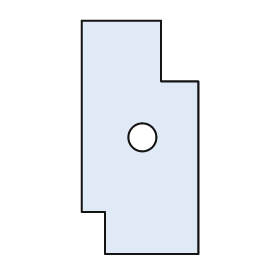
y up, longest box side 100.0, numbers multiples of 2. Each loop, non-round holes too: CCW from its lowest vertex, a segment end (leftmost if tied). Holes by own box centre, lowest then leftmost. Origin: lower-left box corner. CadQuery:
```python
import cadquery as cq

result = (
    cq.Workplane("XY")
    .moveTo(10.0, 0.0)
    .lineTo(50.0, 0.0)
    .lineTo(50.0, 74.0)
    .lineTo(34.0, 74.0)
    .lineTo(34.0, 100.0)
    .lineTo(0.0, 100.0)
    .lineTo(0.0, 18.0)
    .lineTo(10.0, 18.0)
    .close()
    .moveTo(26.0, 50.0)
    .circle(6.0)
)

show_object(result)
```